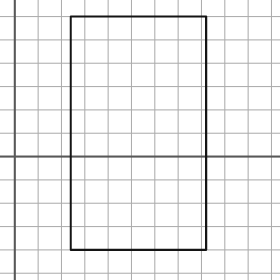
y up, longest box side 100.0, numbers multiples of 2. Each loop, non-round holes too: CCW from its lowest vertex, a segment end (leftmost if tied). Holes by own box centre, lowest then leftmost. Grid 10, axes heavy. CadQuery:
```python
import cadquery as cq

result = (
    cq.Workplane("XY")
    .moveTo(24.0, -40.0)
    .lineTo(82.0, -40.0)
    .lineTo(82.0, 60.0)
    .lineTo(24.0, 60.0)
    .close()
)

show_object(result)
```